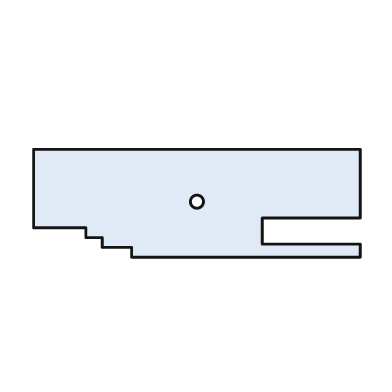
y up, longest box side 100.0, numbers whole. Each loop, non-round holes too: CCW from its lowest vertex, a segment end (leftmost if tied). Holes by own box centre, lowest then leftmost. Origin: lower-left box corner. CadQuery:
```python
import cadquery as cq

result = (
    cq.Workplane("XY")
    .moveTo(30.0, 0.0)
    .lineTo(100.0, 0.0)
    .lineTo(100.0, 4.0)
    .lineTo(70.0, 4.0)
    .lineTo(70.0, 12.0)
    .lineTo(100.0, 12.0)
    .lineTo(100.0, 33.0)
    .lineTo(0.0, 33.0)
    .lineTo(0.0, 9.0)
    .lineTo(16.0, 9.0)
    .lineTo(16.0, 6.0)
    .lineTo(21.0, 6.0)
    .lineTo(21.0, 3.0)
    .lineTo(30.0, 3.0)
    .close()
    .moveTo(50.0, 17.0)
    .circle(2.0)
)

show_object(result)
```